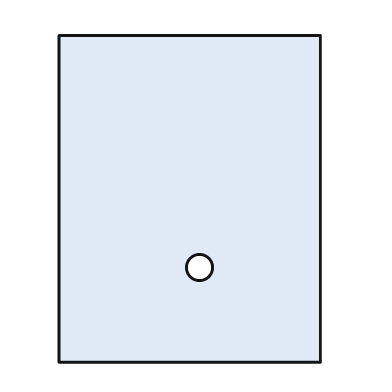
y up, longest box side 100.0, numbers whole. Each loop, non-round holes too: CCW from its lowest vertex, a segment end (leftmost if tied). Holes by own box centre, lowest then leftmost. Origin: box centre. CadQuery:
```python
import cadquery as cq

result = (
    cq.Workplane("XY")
    .moveTo(-40.0, -50.0)
    .lineTo(40.0, -50.0)
    .lineTo(40.0, 50.0)
    .lineTo(-40.0, 50.0)
    .close()
    .moveTo(3.0, -21.0)
    .circle(4.0)
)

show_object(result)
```